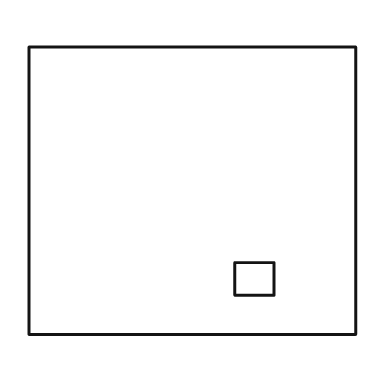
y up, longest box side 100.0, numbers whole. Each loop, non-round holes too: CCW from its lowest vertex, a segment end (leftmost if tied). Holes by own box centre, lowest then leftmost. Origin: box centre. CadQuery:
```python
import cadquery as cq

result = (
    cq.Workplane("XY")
    .moveTo(-50.0, -44.0)
    .lineTo(50.0, -44.0)
    .lineTo(50.0, 44.0)
    .lineTo(-50.0, 44.0)
    .close()
    .moveTo(13.0, -32.0)
    .lineTo(25.0, -32.0)
    .lineTo(25.0, -22.0)
    .lineTo(13.0, -22.0)
    .close()
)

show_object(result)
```